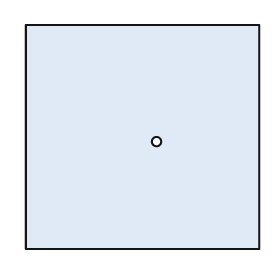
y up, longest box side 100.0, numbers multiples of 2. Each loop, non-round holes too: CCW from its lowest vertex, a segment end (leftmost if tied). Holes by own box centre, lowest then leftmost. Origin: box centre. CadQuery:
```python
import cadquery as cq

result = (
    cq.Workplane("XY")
    .moveTo(-50.0, -48.0)
    .lineTo(50.0, -48.0)
    .lineTo(50.0, 48.0)
    .lineTo(-50.0, 48.0)
    .close()
    .moveTo(6.0, -2.0)
    .circle(2.0)
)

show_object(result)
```